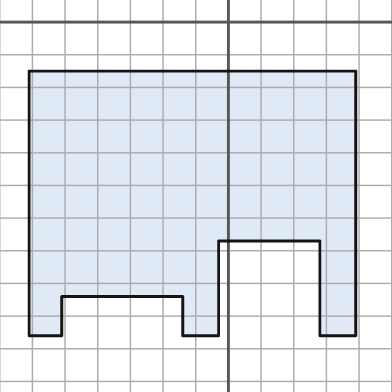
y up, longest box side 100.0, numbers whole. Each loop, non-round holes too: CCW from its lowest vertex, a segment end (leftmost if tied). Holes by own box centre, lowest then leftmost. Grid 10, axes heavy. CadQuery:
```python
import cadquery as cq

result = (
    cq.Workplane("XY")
    .moveTo(-61.0, -96.0)
    .lineTo(-51.0, -96.0)
    .lineTo(-51.0, -84.0)
    .lineTo(-14.0, -84.0)
    .lineTo(-14.0, -96.0)
    .lineTo(-3.0, -96.0)
    .lineTo(-3.0, -67.0)
    .lineTo(28.0, -67.0)
    .lineTo(28.0, -96.0)
    .lineTo(39.0, -96.0)
    .lineTo(39.0, -15.0)
    .lineTo(-61.0, -15.0)
    .close()
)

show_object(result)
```